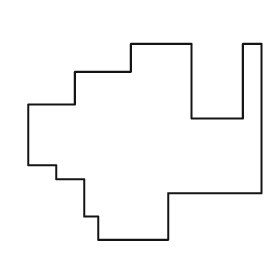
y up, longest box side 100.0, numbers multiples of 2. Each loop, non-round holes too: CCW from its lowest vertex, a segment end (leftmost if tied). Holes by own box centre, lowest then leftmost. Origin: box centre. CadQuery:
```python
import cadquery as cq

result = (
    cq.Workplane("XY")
    .moveTo(-20.0, -42.0)
    .lineTo(10.0, -42.0)
    .lineTo(10.0, -22.0)
    .lineTo(50.0, -22.0)
    .lineTo(50.0, 42.0)
    .lineTo(42.0, 42.0)
    .lineTo(42.0, 10.0)
    .lineTo(20.0, 10.0)
    .lineTo(20.0, 42.0)
    .lineTo(-6.0, 42.0)
    .lineTo(-6.0, 30.0)
    .lineTo(-30.0, 30.0)
    .lineTo(-30.0, 16.0)
    .lineTo(-50.0, 16.0)
    .lineTo(-50.0, -10.0)
    .lineTo(-38.0, -10.0)
    .lineTo(-38.0, -16.0)
    .lineTo(-26.0, -16.0)
    .lineTo(-26.0, -32.0)
    .lineTo(-20.0, -32.0)
    .close()
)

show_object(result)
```